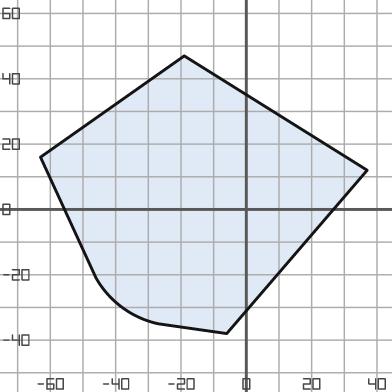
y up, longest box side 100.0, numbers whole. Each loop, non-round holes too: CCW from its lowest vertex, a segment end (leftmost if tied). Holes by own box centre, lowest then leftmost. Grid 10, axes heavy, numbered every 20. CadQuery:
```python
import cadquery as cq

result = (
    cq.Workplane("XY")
    .moveTo(-6.0, -38.0)
    .lineTo(37.0, 12.0)
    .lineTo(-19.0, 47.0)
    .lineTo(-63.0, 16.0)
    .lineTo(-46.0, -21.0)
    .threePointArc((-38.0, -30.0), (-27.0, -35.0))
    .close()
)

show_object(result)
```